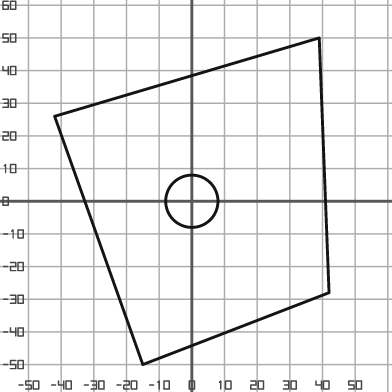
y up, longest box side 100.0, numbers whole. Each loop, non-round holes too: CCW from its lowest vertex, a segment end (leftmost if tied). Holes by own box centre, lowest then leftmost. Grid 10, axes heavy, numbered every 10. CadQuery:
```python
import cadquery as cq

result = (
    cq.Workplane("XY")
    .moveTo(-15.0, -50.0)
    .lineTo(42.0, -28.0)
    .lineTo(39.0, 50.0)
    .lineTo(-42.0, 26.0)
    .close()
    .moveTo(0.0, 0.0)
    .circle(8.0)
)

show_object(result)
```